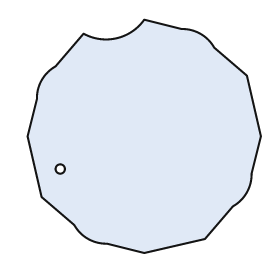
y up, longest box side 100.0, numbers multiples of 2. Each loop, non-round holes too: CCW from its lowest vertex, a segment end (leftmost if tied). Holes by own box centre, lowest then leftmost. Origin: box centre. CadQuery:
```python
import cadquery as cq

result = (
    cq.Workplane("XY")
    .moveTo(0.0, -50.0)
    .lineTo(26.0, -44.0)
    .lineTo(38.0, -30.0)
    .threePointArc((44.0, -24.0), (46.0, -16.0))
    .lineTo(50.0, 0.0)
    .lineTo(44.0, 26.0)
    .lineTo(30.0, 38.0)
    .threePointArc((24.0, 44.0), (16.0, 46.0))
    .lineTo(0.0, 50.0)
    .threePointArc((-12.0, 42.0), (-26.0, 44.0))
    .lineTo(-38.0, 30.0)
    .threePointArc((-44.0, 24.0), (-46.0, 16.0))
    .lineTo(-50.0, 0.0)
    .lineTo(-44.0, -26.0)
    .lineTo(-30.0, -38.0)
    .threePointArc((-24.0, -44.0), (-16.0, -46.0))
    .close()
    .moveTo(-36.0, -14.0)
    .circle(2.0)
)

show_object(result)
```